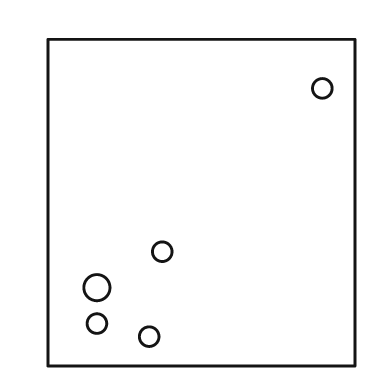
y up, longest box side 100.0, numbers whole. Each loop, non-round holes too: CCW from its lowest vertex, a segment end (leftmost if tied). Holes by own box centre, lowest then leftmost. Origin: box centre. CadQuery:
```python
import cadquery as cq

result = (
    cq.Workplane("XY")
    .moveTo(-47.0, -50.0)
    .lineTo(47.0, -50.0)
    .lineTo(47.0, 50.0)
    .lineTo(-47.0, 50.0)
    .close()
    .moveTo(-16.0, -41.0)
    .circle(3.0)
    .moveTo(-32.0, -37.0)
    .circle(3.0)
    .moveTo(-32.0, -26.0)
    .circle(4.0)
    .moveTo(-12.0, -15.0)
    .circle(3.0)
    .moveTo(37.0, 35.0)
    .circle(3.0)
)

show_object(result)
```